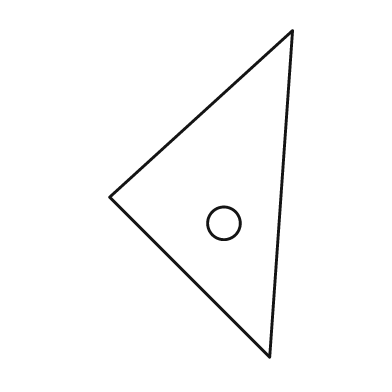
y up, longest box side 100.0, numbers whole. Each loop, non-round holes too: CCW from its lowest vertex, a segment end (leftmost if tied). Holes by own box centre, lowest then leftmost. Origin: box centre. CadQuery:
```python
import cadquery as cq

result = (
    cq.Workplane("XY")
    .moveTo(21.0, -50.0)
    .lineTo(28.0, 50.0)
    .lineTo(-28.0, -1.0)
    .close()
    .moveTo(7.0, -9.0)
    .circle(5.0)
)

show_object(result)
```